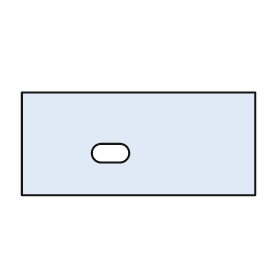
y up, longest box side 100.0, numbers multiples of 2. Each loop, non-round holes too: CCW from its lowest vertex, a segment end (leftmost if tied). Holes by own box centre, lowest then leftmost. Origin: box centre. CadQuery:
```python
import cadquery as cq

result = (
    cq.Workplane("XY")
    .moveTo(-50.0, -22.0)
    .lineTo(50.0, -22.0)
    .lineTo(50.0, 22.0)
    .lineTo(-50.0, 22.0)
    .close()
    .moveTo(-16.0, -8.0)
    .lineTo(-8.0, -8.0)
    .threePointArc((-4.0, -4.0), (-8.0, 0.0))
    .lineTo(-16.0, 0.0)
    .threePointArc((-20.0, -4.0), (-16.0, -8.0))
    .close()
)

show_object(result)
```